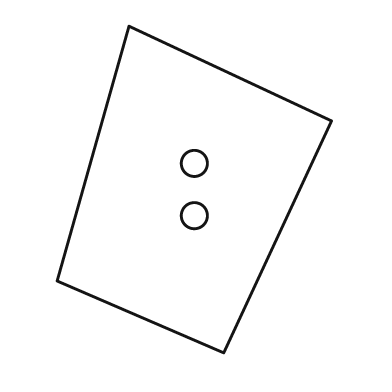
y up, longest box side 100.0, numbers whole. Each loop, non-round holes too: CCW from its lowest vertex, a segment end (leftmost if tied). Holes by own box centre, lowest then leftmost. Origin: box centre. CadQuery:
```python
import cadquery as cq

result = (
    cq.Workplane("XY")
    .moveTo(9.0, -50.0)
    .lineTo(42.0, 21.0)
    .lineTo(-20.0, 50.0)
    .lineTo(-42.0, -28.0)
    .close()
    .moveTo(0.0, -8.0)
    .circle(4.0)
    .moveTo(0.0, 8.0)
    .circle(4.0)
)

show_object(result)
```